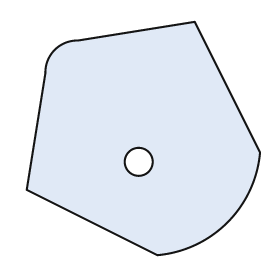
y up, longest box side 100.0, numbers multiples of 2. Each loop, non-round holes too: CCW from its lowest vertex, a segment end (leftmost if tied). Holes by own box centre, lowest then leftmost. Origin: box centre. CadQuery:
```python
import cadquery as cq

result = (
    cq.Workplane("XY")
    .moveTo(6.0, -50.0)
    .threePointArc((36.0, -36.0), (50.0, -6.0))
    .lineTo(22.0, 50.0)
    .lineTo(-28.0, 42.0)
    .threePointArc((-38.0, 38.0), (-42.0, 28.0))
    .lineTo(-50.0, -22.0)
    .close()
    .moveTo(-2.0, -10.0)
    .circle(6.0)
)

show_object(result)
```